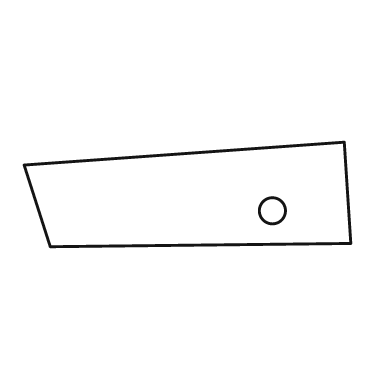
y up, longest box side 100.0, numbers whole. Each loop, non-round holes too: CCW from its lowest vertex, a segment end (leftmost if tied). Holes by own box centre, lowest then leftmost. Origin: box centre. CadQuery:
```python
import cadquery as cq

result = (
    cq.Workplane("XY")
    .moveTo(-42.0, -16.0)
    .lineTo(50.0, -15.0)
    .lineTo(48.0, 16.0)
    .lineTo(-50.0, 9.0)
    .close()
    .moveTo(26.0, -5.0)
    .circle(4.0)
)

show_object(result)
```